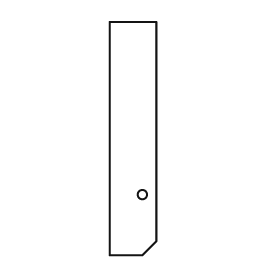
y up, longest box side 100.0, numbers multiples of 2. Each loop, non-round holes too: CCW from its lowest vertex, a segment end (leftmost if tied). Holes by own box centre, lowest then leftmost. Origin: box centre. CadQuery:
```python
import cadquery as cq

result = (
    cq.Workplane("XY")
    .moveTo(-10.0, -50.0)
    .lineTo(4.0, -50.0)
    .lineTo(10.0, -44.0)
    .lineTo(10.0, 50.0)
    .lineTo(-10.0, 50.0)
    .close()
    .moveTo(4.0, -24.0)
    .circle(2.0)
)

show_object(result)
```